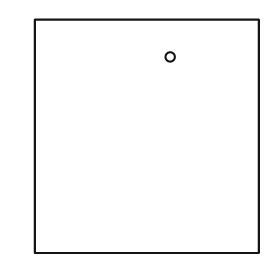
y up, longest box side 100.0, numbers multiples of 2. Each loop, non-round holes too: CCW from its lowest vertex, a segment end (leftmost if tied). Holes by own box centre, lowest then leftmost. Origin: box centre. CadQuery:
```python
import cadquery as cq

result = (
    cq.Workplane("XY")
    .moveTo(-48.0, -50.0)
    .lineTo(48.0, -50.0)
    .lineTo(48.0, 50.0)
    .lineTo(-48.0, 50.0)
    .close()
    .moveTo(10.0, 34.0)
    .circle(2.0)
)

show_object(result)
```